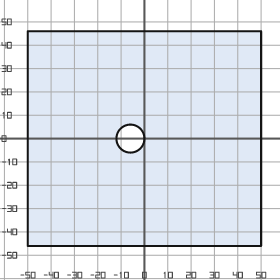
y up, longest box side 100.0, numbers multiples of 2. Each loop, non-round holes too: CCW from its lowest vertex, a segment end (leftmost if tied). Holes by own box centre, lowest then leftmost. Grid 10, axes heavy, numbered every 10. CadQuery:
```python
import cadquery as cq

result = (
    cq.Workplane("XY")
    .moveTo(-50.0, -46.0)
    .lineTo(50.0, -46.0)
    .lineTo(50.0, 46.0)
    .lineTo(-50.0, 46.0)
    .close()
    .moveTo(-6.0, 0.0)
    .circle(6.0)
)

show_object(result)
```